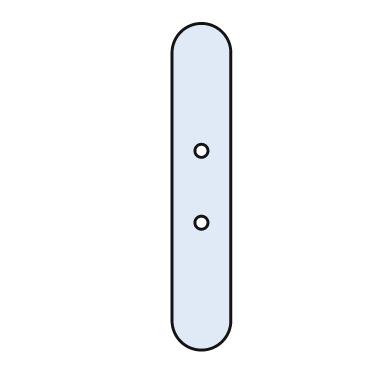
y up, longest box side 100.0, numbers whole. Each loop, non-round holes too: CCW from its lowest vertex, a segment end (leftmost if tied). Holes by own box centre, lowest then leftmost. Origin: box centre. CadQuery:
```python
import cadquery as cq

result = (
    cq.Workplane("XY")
    .moveTo(-9.0, -41.0)
    .threePointArc((0.0, -50.0), (9.0, -41.0))
    .lineTo(9.0, 41.0)
    .threePointArc((0.0, 50.0), (-9.0, 41.0))
    .close()
    .moveTo(0.0, -11.0)
    .circle(2.0)
    .moveTo(0.0, 11.0)
    .circle(2.0)
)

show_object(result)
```